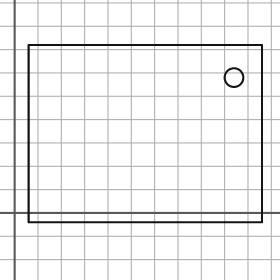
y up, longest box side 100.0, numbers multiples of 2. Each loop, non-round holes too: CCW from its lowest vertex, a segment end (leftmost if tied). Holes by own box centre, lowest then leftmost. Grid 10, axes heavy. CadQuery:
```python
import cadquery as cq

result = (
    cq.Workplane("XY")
    .moveTo(6.0, -4.0)
    .lineTo(106.0, -4.0)
    .lineTo(106.0, 72.0)
    .lineTo(6.0, 72.0)
    .close()
    .moveTo(94.0, 58.0)
    .circle(4.0)
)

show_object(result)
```